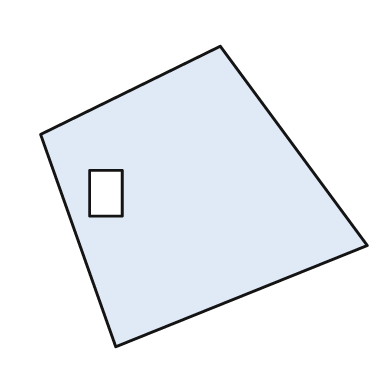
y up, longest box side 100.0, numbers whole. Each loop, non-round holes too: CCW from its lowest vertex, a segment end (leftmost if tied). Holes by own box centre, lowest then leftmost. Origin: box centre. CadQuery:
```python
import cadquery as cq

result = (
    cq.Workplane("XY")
    .moveTo(-27.0, -46.0)
    .lineTo(50.0, -15.0)
    .lineTo(5.0, 46.0)
    .lineTo(-50.0, 19.0)
    .close()
    .moveTo(-35.0, -6.0)
    .lineTo(-25.0, -6.0)
    .lineTo(-25.0, 8.0)
    .lineTo(-35.0, 8.0)
    .close()
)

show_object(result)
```